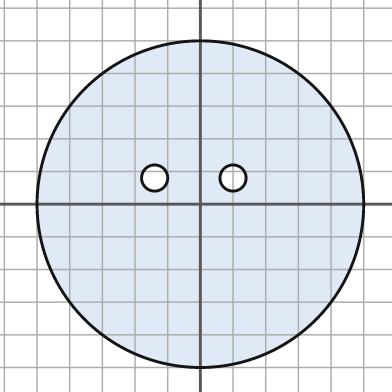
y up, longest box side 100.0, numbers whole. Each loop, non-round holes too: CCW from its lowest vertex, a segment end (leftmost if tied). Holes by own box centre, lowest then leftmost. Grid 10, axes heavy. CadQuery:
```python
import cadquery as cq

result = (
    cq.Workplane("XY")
    .moveTo(0.0, 0.0)
    .circle(50.0)
    .moveTo(-14.0, 8.0)
    .circle(4.0)
    .moveTo(10.0, 8.0)
    .circle(4.0)
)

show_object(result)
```